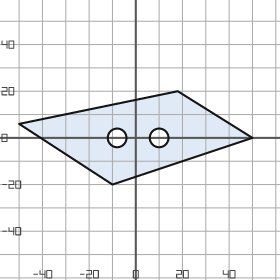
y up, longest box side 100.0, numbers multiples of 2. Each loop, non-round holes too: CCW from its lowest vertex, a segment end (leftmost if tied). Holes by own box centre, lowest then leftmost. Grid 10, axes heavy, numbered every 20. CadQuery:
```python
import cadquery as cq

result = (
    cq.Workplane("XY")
    .moveTo(-10.0, -20.0)
    .lineTo(50.0, 0.0)
    .lineTo(18.0, 20.0)
    .lineTo(-50.0, 6.0)
    .close()
    .moveTo(-8.0, 0.0)
    .circle(4.0)
    .moveTo(10.0, 0.0)
    .circle(4.0)
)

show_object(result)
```